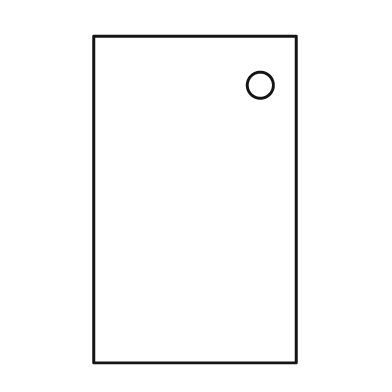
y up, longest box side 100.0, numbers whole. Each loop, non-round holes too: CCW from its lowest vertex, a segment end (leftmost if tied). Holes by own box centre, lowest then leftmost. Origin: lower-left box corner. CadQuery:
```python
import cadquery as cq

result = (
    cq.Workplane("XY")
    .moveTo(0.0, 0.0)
    .lineTo(62.0, 0.0)
    .lineTo(62.0, 100.0)
    .lineTo(0.0, 100.0)
    .close()
    .moveTo(51.0, 85.0)
    .circle(4.0)
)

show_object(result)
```